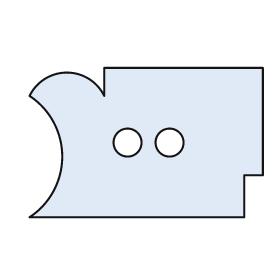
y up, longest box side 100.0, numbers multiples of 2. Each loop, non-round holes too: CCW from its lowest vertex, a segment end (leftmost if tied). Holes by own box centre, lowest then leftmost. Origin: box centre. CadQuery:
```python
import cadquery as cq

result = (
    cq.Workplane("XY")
    .moveTo(-50.0, -32.0)
    .lineTo(42.0, -32.0)
    .lineTo(42.0, -14.0)
    .lineTo(50.0, -14.0)
    .lineTo(50.0, 32.0)
    .lineTo(-18.0, 32.0)
    .lineTo(-18.0, 20.0)
    .threePointArc((-34.0, 30.0), (-50.0, 20.0))
    .threePointArc((-36.0, -6.0), (-50.0, -32.0))
    .close()
    .moveTo(-8.0, 0.0)
    .circle(6.0)
    .moveTo(10.0, 0.0)
    .circle(6.0)
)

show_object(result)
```